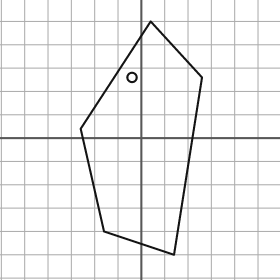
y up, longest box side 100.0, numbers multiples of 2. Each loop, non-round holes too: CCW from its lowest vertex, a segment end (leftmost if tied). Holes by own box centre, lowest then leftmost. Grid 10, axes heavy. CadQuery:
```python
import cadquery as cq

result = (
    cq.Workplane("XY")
    .moveTo(14.0, -50.0)
    .lineTo(26.0, 26.0)
    .lineTo(4.0, 50.0)
    .lineTo(-26.0, 4.0)
    .lineTo(-16.0, -40.0)
    .close()
    .moveTo(-4.0, 26.0)
    .circle(2.0)
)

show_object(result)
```